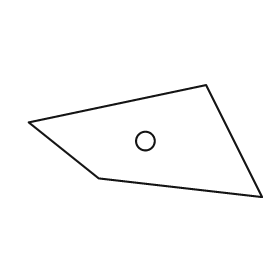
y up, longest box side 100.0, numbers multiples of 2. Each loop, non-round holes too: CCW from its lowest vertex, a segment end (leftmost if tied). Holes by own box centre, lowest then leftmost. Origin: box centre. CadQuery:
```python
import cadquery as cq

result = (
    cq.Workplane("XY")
    .moveTo(50.0, -24.0)
    .lineTo(26.0, 24.0)
    .lineTo(-50.0, 8.0)
    .lineTo(-20.0, -16.0)
    .close()
    .moveTo(0.0, 0.0)
    .circle(4.0)
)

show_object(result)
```